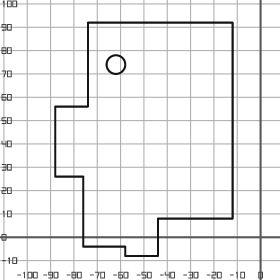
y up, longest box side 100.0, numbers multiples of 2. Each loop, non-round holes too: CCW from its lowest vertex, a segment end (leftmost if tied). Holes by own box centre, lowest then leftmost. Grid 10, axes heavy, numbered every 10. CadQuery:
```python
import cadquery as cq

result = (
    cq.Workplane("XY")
    .moveTo(-58.0, -8.0)
    .lineTo(-44.0, -8.0)
    .lineTo(-44.0, 8.0)
    .lineTo(-12.0, 8.0)
    .lineTo(-12.0, 92.0)
    .lineTo(-74.0, 92.0)
    .lineTo(-74.0, 56.0)
    .lineTo(-88.0, 56.0)
    .lineTo(-88.0, 26.0)
    .lineTo(-76.0, 26.0)
    .lineTo(-76.0, -4.0)
    .lineTo(-58.0, -4.0)
    .close()
    .moveTo(-62.0, 74.0)
    .circle(4.0)
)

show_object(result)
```